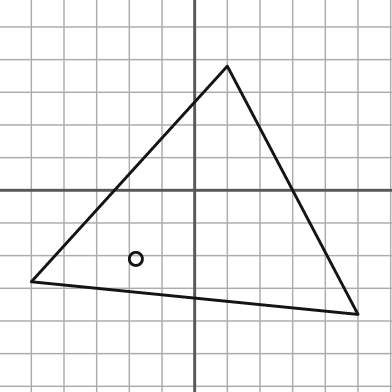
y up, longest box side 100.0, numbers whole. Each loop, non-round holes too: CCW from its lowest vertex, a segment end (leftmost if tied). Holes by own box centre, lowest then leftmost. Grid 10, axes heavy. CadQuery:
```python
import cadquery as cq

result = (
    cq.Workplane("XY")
    .moveTo(50.0, -38.0)
    .lineTo(10.0, 38.0)
    .lineTo(-50.0, -28.0)
    .close()
    .moveTo(-18.0, -21.0)
    .circle(2.0)
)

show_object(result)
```